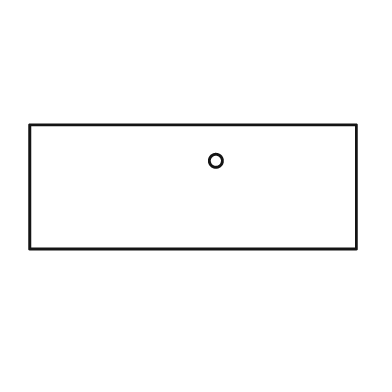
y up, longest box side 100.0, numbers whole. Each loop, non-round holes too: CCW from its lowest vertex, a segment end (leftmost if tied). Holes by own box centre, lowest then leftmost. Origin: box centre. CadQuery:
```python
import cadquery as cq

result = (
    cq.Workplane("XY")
    .moveTo(-50.0, -19.0)
    .lineTo(50.0, -19.0)
    .lineTo(50.0, 19.0)
    .lineTo(-50.0, 19.0)
    .close()
    .moveTo(7.0, 8.0)
    .circle(2.0)
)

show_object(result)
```